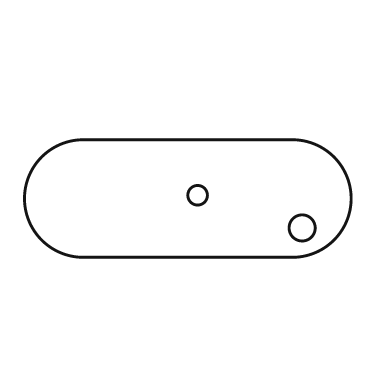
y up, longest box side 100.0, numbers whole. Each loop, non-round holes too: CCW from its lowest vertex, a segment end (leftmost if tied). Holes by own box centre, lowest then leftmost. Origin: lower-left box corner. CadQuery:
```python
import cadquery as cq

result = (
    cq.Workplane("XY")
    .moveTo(18.0, 0.0)
    .lineTo(82.0, 0.0)
    .threePointArc((100.0, 18.0), (82.0, 36.0))
    .lineTo(18.0, 36.0)
    .threePointArc((0.0, 18.0), (18.0, 0.0))
    .close()
    .moveTo(85.0, 9.0)
    .circle(4.0)
    .moveTo(53.0, 19.0)
    .circle(3.0)
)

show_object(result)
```